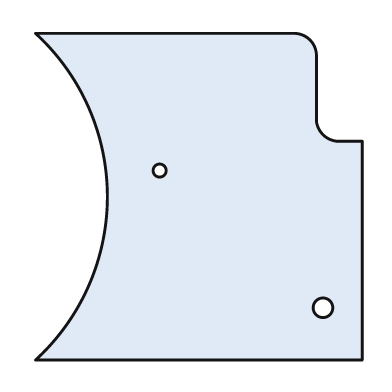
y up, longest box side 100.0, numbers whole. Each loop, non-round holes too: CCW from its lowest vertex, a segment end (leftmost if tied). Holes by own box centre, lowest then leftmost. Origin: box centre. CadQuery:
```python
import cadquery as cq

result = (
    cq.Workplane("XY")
    .moveTo(-50.0, -50.0)
    .lineTo(50.0, -50.0)
    .lineTo(50.0, 17.0)
    .lineTo(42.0, 17.0)
    .threePointArc((38.0, 19.0), (36.0, 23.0))
    .lineTo(36.0, 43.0)
    .threePointArc((34.0, 48.0), (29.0, 50.0))
    .lineTo(-50.0, 50.0)
    .threePointArc((-28.0, 0.0), (-50.0, -50.0))
    .close()
    .moveTo(38.0, -34.0)
    .circle(3.0)
    .moveTo(-12.0, 8.0)
    .circle(2.0)
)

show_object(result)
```